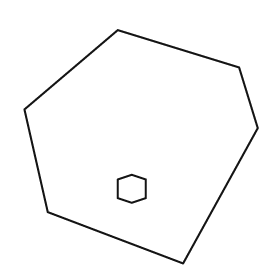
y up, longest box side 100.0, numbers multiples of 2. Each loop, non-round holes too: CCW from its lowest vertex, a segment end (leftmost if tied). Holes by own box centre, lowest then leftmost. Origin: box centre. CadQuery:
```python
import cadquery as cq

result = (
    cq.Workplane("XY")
    .moveTo(18.0, -50.0)
    .lineTo(50.0, 8.0)
    .lineTo(42.0, 34.0)
    .lineTo(-10.0, 50.0)
    .lineTo(-50.0, 16.0)
    .lineTo(-40.0, -28.0)
    .close()
    .moveTo(-4.0, -24.0)
    .lineTo(2.0, -22.0)
    .lineTo(2.0, -14.0)
    .lineTo(-4.0, -12.0)
    .lineTo(-10.0, -14.0)
    .lineTo(-10.0, -22.0)
    .close()
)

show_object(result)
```